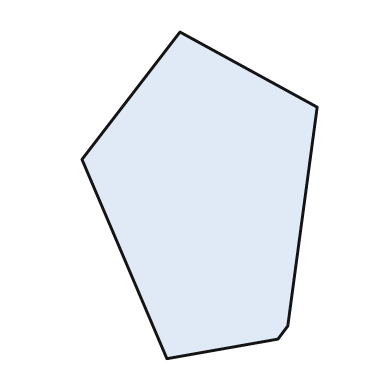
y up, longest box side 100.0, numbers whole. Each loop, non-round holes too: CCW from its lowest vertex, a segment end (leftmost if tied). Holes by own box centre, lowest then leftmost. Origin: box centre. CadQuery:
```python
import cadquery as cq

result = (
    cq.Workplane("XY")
    .moveTo(-10.0, -50.0)
    .lineTo(24.0, -44.0)
    .lineTo(27.0, -40.0)
    .lineTo(36.0, 27.0)
    .lineTo(-6.0, 50.0)
    .lineTo(-36.0, 11.0)
    .close()
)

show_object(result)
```